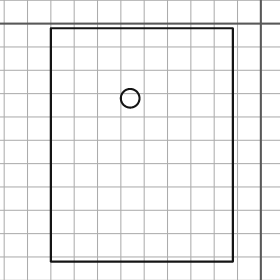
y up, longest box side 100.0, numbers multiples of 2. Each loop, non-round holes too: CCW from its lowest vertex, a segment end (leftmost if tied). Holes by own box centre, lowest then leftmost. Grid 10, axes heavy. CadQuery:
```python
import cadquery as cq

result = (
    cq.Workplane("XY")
    .moveTo(-90.0, -102.0)
    .lineTo(-12.0, -102.0)
    .lineTo(-12.0, -2.0)
    .lineTo(-90.0, -2.0)
    .close()
    .moveTo(-56.0, -32.0)
    .circle(4.0)
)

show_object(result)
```